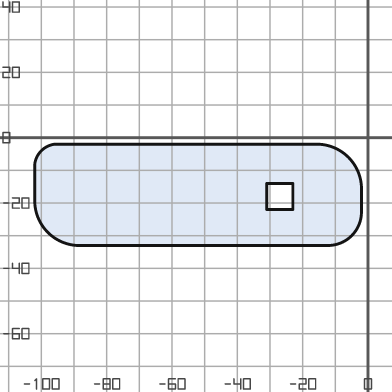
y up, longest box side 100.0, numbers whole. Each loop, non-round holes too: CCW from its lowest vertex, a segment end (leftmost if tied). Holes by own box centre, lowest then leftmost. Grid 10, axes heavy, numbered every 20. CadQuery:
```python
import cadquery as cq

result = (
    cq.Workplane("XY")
    .moveTo(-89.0, -33.0)
    .lineTo(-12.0, -33.0)
    .threePointArc((-5.0, -30.0), (-2.0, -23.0))
    .lineTo(-2.0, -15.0)
    .threePointArc((-6.0, -6.0), (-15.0, -2.0))
    .lineTo(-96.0, -2.0)
    .threePointArc((-100.0, -4.0), (-102.0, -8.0))
    .lineTo(-102.0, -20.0)
    .threePointArc((-98.0, -29.0), (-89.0, -33.0))
    .close()
    .moveTo(-31.0, -22.0)
    .lineTo(-23.0, -22.0)
    .lineTo(-23.0, -14.0)
    .lineTo(-31.0, -14.0)
    .close()
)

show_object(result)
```